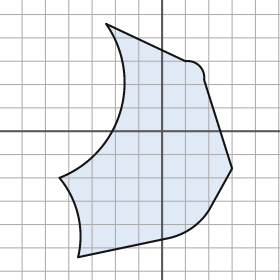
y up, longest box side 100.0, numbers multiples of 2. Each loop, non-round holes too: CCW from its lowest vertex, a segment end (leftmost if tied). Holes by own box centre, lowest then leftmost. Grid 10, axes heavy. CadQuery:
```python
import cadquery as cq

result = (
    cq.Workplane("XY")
    .moveTo(-36.0, -54.0)
    .lineTo(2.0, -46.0)
    .threePointArc((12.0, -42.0), (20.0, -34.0))
    .lineTo(30.0, -16.0)
    .lineTo(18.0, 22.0)
    .threePointArc((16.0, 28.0), (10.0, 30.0))
    .lineTo(-24.0, 46.0)
    .threePointArc((-18.0, 8.0), (-44.0, -20.0))
    .threePointArc((-36.0, -36.0), (-36.0, -54.0))
    .close()
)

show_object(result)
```